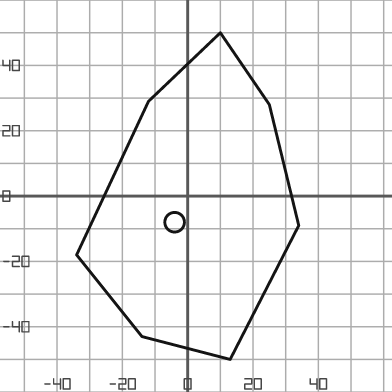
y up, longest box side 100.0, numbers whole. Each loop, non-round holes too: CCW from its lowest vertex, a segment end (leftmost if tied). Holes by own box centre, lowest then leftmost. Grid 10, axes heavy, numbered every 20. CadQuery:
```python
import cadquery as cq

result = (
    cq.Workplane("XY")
    .moveTo(13.0, -50.0)
    .lineTo(34.0, -9.0)
    .lineTo(25.0, 28.0)
    .lineTo(10.0, 50.0)
    .lineTo(-12.0, 29.0)
    .lineTo(-34.0, -18.0)
    .lineTo(-14.0, -43.0)
    .close()
    .moveTo(-4.0, -8.0)
    .circle(3.0)
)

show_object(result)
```